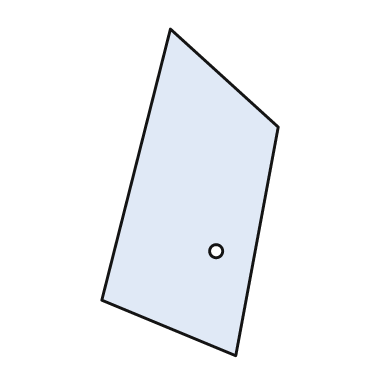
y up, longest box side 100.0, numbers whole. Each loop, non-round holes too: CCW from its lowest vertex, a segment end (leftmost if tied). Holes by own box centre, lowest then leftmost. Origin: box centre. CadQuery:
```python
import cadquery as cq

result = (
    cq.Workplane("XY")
    .moveTo(14.0, -50.0)
    .lineTo(27.0, 20.0)
    .lineTo(-6.0, 50.0)
    .lineTo(-27.0, -33.0)
    .close()
    .moveTo(8.0, -18.0)
    .circle(2.0)
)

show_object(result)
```